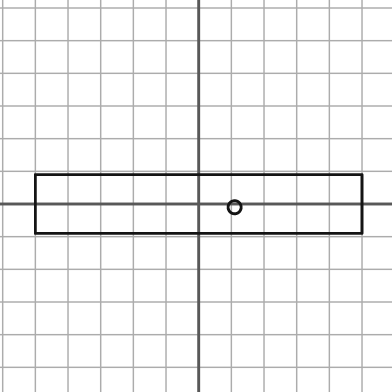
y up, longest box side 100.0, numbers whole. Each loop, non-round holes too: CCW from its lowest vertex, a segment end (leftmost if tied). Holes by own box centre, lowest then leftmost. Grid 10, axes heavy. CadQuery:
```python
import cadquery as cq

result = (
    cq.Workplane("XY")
    .moveTo(-50.0, -9.0)
    .lineTo(50.0, -9.0)
    .lineTo(50.0, 9.0)
    .lineTo(-50.0, 9.0)
    .close()
    .moveTo(11.0, -1.0)
    .circle(2.0)
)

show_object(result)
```